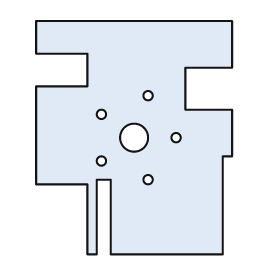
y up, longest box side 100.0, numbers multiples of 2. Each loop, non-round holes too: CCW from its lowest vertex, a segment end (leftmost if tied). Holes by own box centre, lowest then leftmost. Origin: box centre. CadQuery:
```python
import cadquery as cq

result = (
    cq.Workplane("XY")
    .moveTo(-20.0, -50.0)
    .lineTo(-16.0, -50.0)
    .lineTo(-16.0, -18.0)
    .lineTo(-10.0, -18.0)
    .lineTo(-10.0, -50.0)
    .lineTo(38.0, -50.0)
    .lineTo(38.0, -8.0)
    .lineTo(42.0, -8.0)
    .lineTo(42.0, 12.0)
    .lineTo(22.0, 12.0)
    .lineTo(22.0, 30.0)
    .lineTo(42.0, 30.0)
    .lineTo(42.0, 50.0)
    .lineTo(-42.0, 50.0)
    .lineTo(-42.0, 36.0)
    .lineTo(-20.0, 36.0)
    .lineTo(-20.0, 22.0)
    .lineTo(-42.0, 22.0)
    .lineTo(-42.0, -20.0)
    .lineTo(-20.0, -20.0)
    .close()
    .moveTo(6.0, -18.0)
    .circle(2.0)
    .moveTo(-14.0, -10.0)
    .circle(2.0)
    .moveTo(0.0, 0.0)
    .circle(6.0)
    .moveTo(18.0, 0.0)
    .circle(2.0)
    .moveTo(-14.0, 10.0)
    .circle(2.0)
    .moveTo(6.0, 18.0)
    .circle(2.0)
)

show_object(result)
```